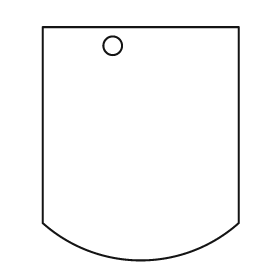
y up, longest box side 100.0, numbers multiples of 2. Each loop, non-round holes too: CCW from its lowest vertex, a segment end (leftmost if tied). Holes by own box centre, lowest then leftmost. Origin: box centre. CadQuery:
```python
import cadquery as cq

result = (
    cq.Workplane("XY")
    .moveTo(-42.0, -34.0)
    .threePointArc((0.0, -50.0), (42.0, -34.0))
    .lineTo(42.0, 50.0)
    .lineTo(-42.0, 50.0)
    .close()
    .moveTo(-12.0, 42.0)
    .circle(4.0)
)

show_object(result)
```